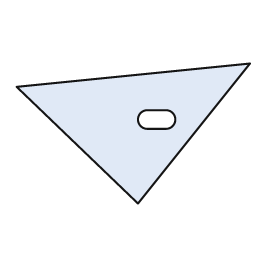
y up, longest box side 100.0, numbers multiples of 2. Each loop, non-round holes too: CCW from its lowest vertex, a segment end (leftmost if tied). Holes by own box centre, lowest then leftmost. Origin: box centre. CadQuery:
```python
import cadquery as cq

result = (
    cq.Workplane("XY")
    .moveTo(2.0, -30.0)
    .lineTo(50.0, 30.0)
    .lineTo(-50.0, 20.0)
    .close()
    .moveTo(6.0, 2.0)
    .lineTo(14.0, 2.0)
    .threePointArc((18.0, 6.0), (14.0, 10.0))
    .lineTo(6.0, 10.0)
    .threePointArc((2.0, 6.0), (6.0, 2.0))
    .close()
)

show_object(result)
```